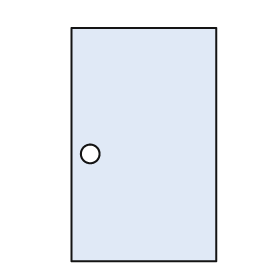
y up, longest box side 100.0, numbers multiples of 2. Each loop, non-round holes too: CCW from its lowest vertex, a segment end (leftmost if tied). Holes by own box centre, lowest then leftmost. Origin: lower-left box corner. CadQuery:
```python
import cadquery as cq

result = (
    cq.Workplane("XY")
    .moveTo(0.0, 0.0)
    .lineTo(62.0, 0.0)
    .lineTo(62.0, 100.0)
    .lineTo(0.0, 100.0)
    .close()
    .moveTo(8.0, 46.0)
    .circle(4.0)
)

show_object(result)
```